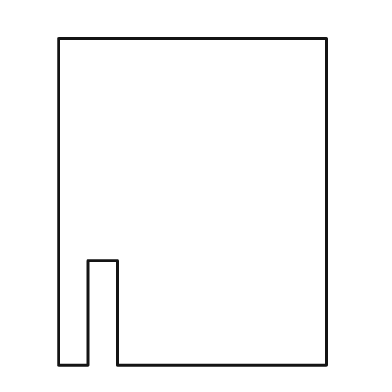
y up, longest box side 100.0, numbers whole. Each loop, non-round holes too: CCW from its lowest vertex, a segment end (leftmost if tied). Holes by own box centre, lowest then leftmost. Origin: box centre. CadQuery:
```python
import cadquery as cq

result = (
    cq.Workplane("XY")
    .moveTo(-41.0, -50.0)
    .lineTo(-32.0, -50.0)
    .lineTo(-32.0, -18.0)
    .lineTo(-23.0, -18.0)
    .lineTo(-23.0, -50.0)
    .lineTo(41.0, -50.0)
    .lineTo(41.0, 50.0)
    .lineTo(-41.0, 50.0)
    .close()
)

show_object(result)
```